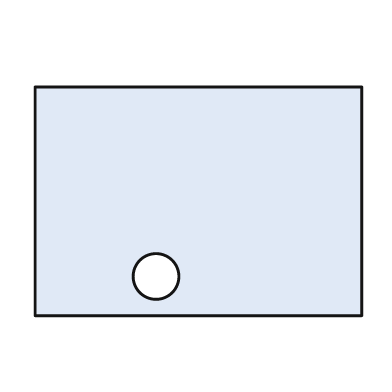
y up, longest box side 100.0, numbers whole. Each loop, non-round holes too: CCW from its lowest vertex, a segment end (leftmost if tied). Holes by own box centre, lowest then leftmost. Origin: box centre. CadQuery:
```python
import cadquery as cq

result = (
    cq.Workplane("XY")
    .moveTo(-50.0, -35.0)
    .lineTo(50.0, -35.0)
    .lineTo(50.0, 35.0)
    .lineTo(-50.0, 35.0)
    .close()
    .moveTo(-13.0, -23.0)
    .circle(7.0)
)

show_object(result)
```